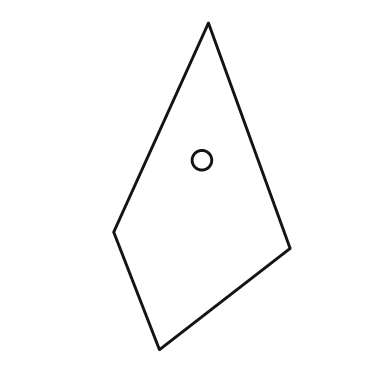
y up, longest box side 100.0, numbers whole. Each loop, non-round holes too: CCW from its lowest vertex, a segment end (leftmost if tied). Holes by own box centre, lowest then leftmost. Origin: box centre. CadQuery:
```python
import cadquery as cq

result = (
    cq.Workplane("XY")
    .moveTo(-13.0, -50.0)
    .lineTo(27.0, -19.0)
    .lineTo(2.0, 50.0)
    .lineTo(-27.0, -14.0)
    .close()
    .moveTo(0.0, 8.0)
    .circle(3.0)
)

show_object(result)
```